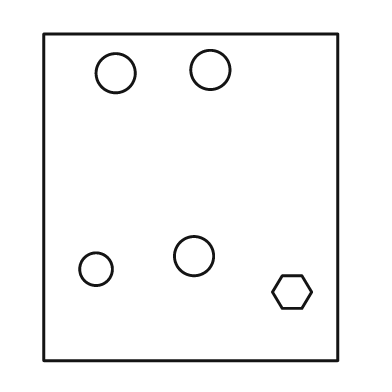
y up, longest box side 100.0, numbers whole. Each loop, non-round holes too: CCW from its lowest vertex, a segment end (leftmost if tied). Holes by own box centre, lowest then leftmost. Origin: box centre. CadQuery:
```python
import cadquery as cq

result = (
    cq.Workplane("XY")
    .moveTo(-45.0, -50.0)
    .lineTo(45.0, -50.0)
    .lineTo(45.0, 50.0)
    .lineTo(-45.0, 50.0)
    .close()
    .moveTo(28.0, -34.0)
    .lineTo(34.0, -34.0)
    .lineTo(37.0, -29.0)
    .lineTo(34.0, -24.0)
    .lineTo(28.0, -24.0)
    .lineTo(25.0, -29.0)
    .close()
    .moveTo(-29.0, -22.0)
    .circle(5.0)
    .moveTo(1.0, -18.0)
    .circle(6.0)
    .moveTo(-23.0, 38.0)
    .circle(6.0)
    .moveTo(6.0, 39.0)
    .circle(6.0)
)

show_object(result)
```